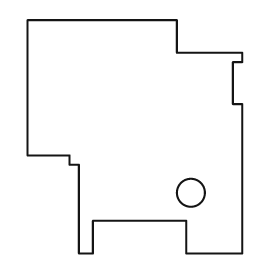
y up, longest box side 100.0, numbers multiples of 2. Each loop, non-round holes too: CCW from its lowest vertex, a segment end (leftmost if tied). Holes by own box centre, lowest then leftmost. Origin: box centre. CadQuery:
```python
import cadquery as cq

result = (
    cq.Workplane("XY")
    .moveTo(-24.0, -50.0)
    .lineTo(-18.0, -50.0)
    .lineTo(-18.0, -36.0)
    .lineTo(22.0, -36.0)
    .lineTo(22.0, -50.0)
    .lineTo(46.0, -50.0)
    .lineTo(46.0, 14.0)
    .lineTo(42.0, 14.0)
    .lineTo(42.0, 32.0)
    .lineTo(46.0, 32.0)
    .lineTo(46.0, 36.0)
    .lineTo(18.0, 36.0)
    .lineTo(18.0, 50.0)
    .lineTo(-46.0, 50.0)
    .lineTo(-46.0, -8.0)
    .lineTo(-28.0, -8.0)
    .lineTo(-28.0, -12.0)
    .lineTo(-24.0, -12.0)
    .close()
    .moveTo(24.0, -24.0)
    .circle(6.0)
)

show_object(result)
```